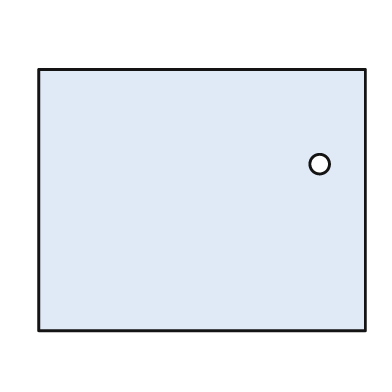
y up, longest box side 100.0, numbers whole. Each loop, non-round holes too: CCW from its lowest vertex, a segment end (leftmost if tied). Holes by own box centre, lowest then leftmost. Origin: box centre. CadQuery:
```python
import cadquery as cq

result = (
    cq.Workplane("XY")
    .moveTo(-50.0, -40.0)
    .lineTo(50.0, -40.0)
    .lineTo(50.0, 40.0)
    .lineTo(-50.0, 40.0)
    .close()
    .moveTo(36.0, 11.0)
    .circle(3.0)
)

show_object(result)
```